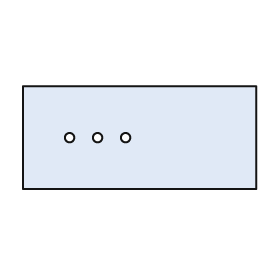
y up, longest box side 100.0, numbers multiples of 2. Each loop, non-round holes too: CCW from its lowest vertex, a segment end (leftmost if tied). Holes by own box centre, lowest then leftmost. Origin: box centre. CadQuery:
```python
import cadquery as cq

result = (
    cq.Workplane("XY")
    .moveTo(-50.0, -22.0)
    .lineTo(50.0, -22.0)
    .lineTo(50.0, 22.0)
    .lineTo(-50.0, 22.0)
    .close()
    .moveTo(-30.0, 0.0)
    .circle(2.0)
    .moveTo(-18.0, 0.0)
    .circle(2.0)
    .moveTo(-6.0, 0.0)
    .circle(2.0)
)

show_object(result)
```